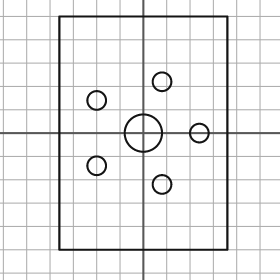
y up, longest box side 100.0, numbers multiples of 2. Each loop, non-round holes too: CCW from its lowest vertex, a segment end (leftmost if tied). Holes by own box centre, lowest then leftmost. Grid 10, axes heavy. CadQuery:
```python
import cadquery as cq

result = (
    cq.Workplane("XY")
    .moveTo(-36.0, -50.0)
    .lineTo(36.0, -50.0)
    .lineTo(36.0, 50.0)
    .lineTo(-36.0, 50.0)
    .close()
    .moveTo(8.0, -22.0)
    .circle(4.0)
    .moveTo(-20.0, -14.0)
    .circle(4.0)
    .moveTo(0.0, 0.0)
    .circle(8.0)
    .moveTo(24.0, 0.0)
    .circle(4.0)
    .moveTo(-20.0, 14.0)
    .circle(4.0)
    .moveTo(8.0, 22.0)
    .circle(4.0)
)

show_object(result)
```